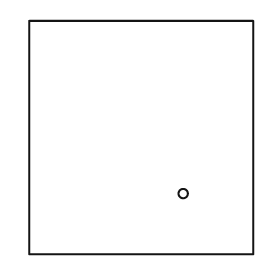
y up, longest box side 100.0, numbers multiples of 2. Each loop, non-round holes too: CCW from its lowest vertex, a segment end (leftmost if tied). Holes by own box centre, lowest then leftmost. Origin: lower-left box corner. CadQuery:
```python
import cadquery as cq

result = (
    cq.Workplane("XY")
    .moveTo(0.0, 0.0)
    .lineTo(96.0, 0.0)
    .lineTo(96.0, 100.0)
    .lineTo(0.0, 100.0)
    .close()
    .moveTo(66.0, 26.0)
    .circle(2.0)
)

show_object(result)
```